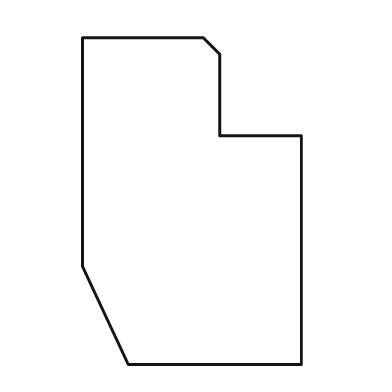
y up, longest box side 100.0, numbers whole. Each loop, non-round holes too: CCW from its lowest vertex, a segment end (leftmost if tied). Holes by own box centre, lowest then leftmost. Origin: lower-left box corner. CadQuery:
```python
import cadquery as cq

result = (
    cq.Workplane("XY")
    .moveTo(14.0, 0.0)
    .lineTo(67.0, 0.0)
    .lineTo(67.0, 70.0)
    .lineTo(42.0, 70.0)
    .lineTo(42.0, 95.0)
    .lineTo(37.0, 100.0)
    .lineTo(0.0, 100.0)
    .lineTo(0.0, 30.0)
    .close()
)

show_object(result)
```